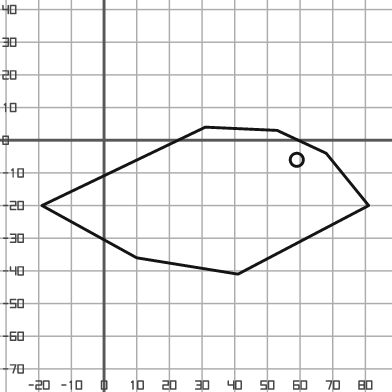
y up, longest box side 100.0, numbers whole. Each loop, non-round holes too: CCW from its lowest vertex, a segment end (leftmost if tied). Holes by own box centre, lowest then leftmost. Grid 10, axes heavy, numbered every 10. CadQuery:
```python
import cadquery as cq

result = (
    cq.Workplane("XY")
    .moveTo(41.0, -41.0)
    .lineTo(81.0, -20.0)
    .lineTo(68.0, -4.0)
    .lineTo(53.0, 3.0)
    .lineTo(31.0, 4.0)
    .lineTo(-19.0, -20.0)
    .lineTo(10.0, -36.0)
    .close()
    .moveTo(59.0, -6.0)
    .circle(2.0)
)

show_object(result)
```